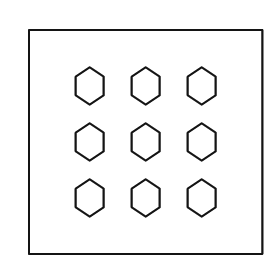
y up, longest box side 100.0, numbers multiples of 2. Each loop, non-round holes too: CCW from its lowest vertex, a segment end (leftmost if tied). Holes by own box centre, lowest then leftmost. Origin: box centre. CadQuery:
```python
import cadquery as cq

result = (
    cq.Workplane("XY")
    .moveTo(-50.0, -48.0)
    .lineTo(50.0, -48.0)
    .lineTo(50.0, 48.0)
    .lineTo(-50.0, 48.0)
    .close()
    .moveTo(-24.0, -32.0)
    .lineTo(-18.0, -28.0)
    .lineTo(-18.0, -20.0)
    .lineTo(-24.0, -16.0)
    .lineTo(-30.0, -20.0)
    .lineTo(-30.0, -28.0)
    .close()
    .moveTo(0.0, -32.0)
    .lineTo(6.0, -28.0)
    .lineTo(6.0, -20.0)
    .lineTo(0.0, -16.0)
    .lineTo(-6.0, -20.0)
    .lineTo(-6.0, -28.0)
    .close()
    .moveTo(24.0, -32.0)
    .lineTo(30.0, -28.0)
    .lineTo(30.0, -20.0)
    .lineTo(24.0, -16.0)
    .lineTo(18.0, -20.0)
    .lineTo(18.0, -28.0)
    .close()
    .moveTo(-24.0, -8.0)
    .lineTo(-18.0, -4.0)
    .lineTo(-18.0, 4.0)
    .lineTo(-24.0, 8.0)
    .lineTo(-30.0, 4.0)
    .lineTo(-30.0, -4.0)
    .close()
    .moveTo(0.0, -8.0)
    .lineTo(6.0, -4.0)
    .lineTo(6.0, 4.0)
    .lineTo(0.0, 8.0)
    .lineTo(-6.0, 4.0)
    .lineTo(-6.0, -4.0)
    .close()
    .moveTo(24.0, -8.0)
    .lineTo(30.0, -4.0)
    .lineTo(30.0, 4.0)
    .lineTo(24.0, 8.0)
    .lineTo(18.0, 4.0)
    .lineTo(18.0, -4.0)
    .close()
    .moveTo(-24.0, 16.0)
    .lineTo(-18.0, 20.0)
    .lineTo(-18.0, 28.0)
    .lineTo(-24.0, 32.0)
    .lineTo(-30.0, 28.0)
    .lineTo(-30.0, 20.0)
    .close()
    .moveTo(0.0, 16.0)
    .lineTo(6.0, 20.0)
    .lineTo(6.0, 28.0)
    .lineTo(0.0, 32.0)
    .lineTo(-6.0, 28.0)
    .lineTo(-6.0, 20.0)
    .close()
    .moveTo(24.0, 16.0)
    .lineTo(30.0, 20.0)
    .lineTo(30.0, 28.0)
    .lineTo(24.0, 32.0)
    .lineTo(18.0, 28.0)
    .lineTo(18.0, 20.0)
    .close()
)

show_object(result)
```